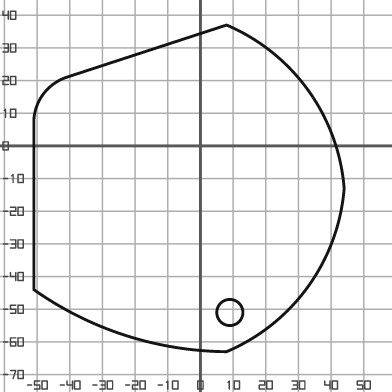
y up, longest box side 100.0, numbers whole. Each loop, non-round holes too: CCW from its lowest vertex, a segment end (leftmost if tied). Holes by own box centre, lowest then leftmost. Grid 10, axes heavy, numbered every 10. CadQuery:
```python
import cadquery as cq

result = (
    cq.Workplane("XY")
    .moveTo(8.0, -63.0)
    .threePointArc((33.0, -43.0), (44.0, -13.0))
    .threePointArc((33.0, 17.0), (8.0, 37.0))
    .lineTo(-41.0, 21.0)
    .threePointArc((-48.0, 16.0), (-51.0, 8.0))
    .lineTo(-51.0, -44.0)
    .threePointArc((-23.0, -58.0), (8.0, -63.0))
    .close()
    .moveTo(9.0, -51.0)
    .circle(4.0)
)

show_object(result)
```